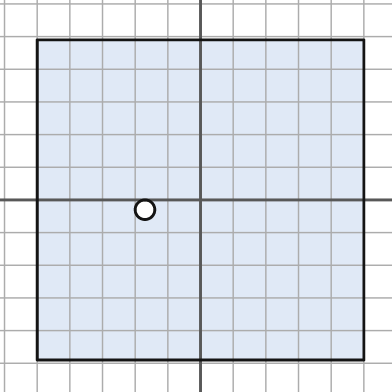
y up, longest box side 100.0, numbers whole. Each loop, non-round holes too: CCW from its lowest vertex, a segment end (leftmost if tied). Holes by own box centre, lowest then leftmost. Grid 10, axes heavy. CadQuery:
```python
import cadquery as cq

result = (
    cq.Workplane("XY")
    .moveTo(-50.0, -49.0)
    .lineTo(50.0, -49.0)
    .lineTo(50.0, 49.0)
    .lineTo(-50.0, 49.0)
    .close()
    .moveTo(-17.0, -3.0)
    .circle(3.0)
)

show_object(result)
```